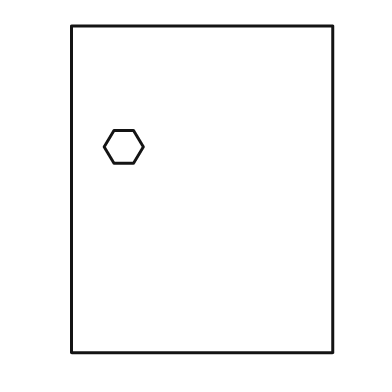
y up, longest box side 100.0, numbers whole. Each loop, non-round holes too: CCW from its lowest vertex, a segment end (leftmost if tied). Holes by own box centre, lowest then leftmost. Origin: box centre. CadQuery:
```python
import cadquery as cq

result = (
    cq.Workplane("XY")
    .moveTo(-40.0, -50.0)
    .lineTo(40.0, -50.0)
    .lineTo(40.0, 50.0)
    .lineTo(-40.0, 50.0)
    .close()
    .moveTo(-27.0, 8.0)
    .lineTo(-21.0, 8.0)
    .lineTo(-18.0, 13.0)
    .lineTo(-21.0, 18.0)
    .lineTo(-27.0, 18.0)
    .lineTo(-30.0, 13.0)
    .close()
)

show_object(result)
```